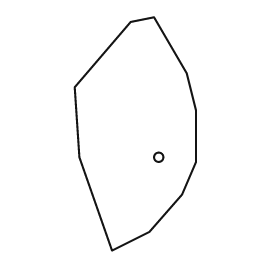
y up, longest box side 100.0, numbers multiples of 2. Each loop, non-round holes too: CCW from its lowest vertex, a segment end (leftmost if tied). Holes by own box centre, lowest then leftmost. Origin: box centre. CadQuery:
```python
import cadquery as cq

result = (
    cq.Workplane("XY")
    .moveTo(-10.0, -50.0)
    .lineTo(6.0, -42.0)
    .lineTo(20.0, -26.0)
    .lineTo(26.0, -12.0)
    .lineTo(26.0, 10.0)
    .lineTo(22.0, 26.0)
    .lineTo(8.0, 50.0)
    .lineTo(-2.0, 48.0)
    .lineTo(-26.0, 20.0)
    .lineTo(-24.0, -10.0)
    .close()
    .moveTo(10.0, -10.0)
    .circle(2.0)
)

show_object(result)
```